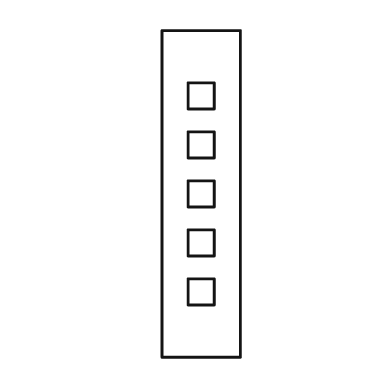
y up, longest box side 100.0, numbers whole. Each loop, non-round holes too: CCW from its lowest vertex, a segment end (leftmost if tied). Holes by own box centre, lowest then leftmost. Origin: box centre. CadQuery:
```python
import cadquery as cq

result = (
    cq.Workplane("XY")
    .moveTo(-12.0, -50.0)
    .lineTo(12.0, -50.0)
    .lineTo(12.0, 50.0)
    .lineTo(-12.0, 50.0)
    .close()
    .moveTo(-4.0, -34.0)
    .lineTo(4.0, -34.0)
    .lineTo(4.0, -26.0)
    .lineTo(-4.0, -26.0)
    .close()
    .moveTo(-4.0, -19.0)
    .lineTo(4.0, -19.0)
    .lineTo(4.0, -11.0)
    .lineTo(-4.0, -11.0)
    .close()
    .moveTo(-4.0, -4.0)
    .lineTo(4.0, -4.0)
    .lineTo(4.0, 4.0)
    .lineTo(-4.0, 4.0)
    .close()
    .moveTo(-4.0, 11.0)
    .lineTo(4.0, 11.0)
    .lineTo(4.0, 19.0)
    .lineTo(-4.0, 19.0)
    .close()
    .moveTo(-4.0, 26.0)
    .lineTo(4.0, 26.0)
    .lineTo(4.0, 34.0)
    .lineTo(-4.0, 34.0)
    .close()
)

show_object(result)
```